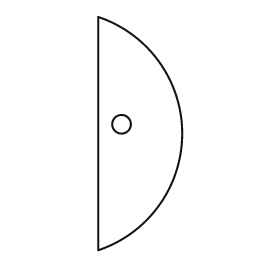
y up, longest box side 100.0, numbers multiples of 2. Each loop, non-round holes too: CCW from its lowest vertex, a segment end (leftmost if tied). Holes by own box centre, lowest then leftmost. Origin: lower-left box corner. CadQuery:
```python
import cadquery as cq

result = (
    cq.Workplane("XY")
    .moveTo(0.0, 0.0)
    .threePointArc((36.0, 50.0), (0.0, 100.0))
    .close()
    .moveTo(10.0, 54.0)
    .circle(4.0)
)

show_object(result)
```